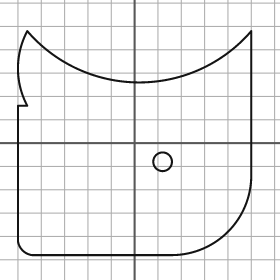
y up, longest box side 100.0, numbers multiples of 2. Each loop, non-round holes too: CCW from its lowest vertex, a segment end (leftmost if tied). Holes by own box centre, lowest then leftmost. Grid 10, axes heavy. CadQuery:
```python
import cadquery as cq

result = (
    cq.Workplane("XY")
    .moveTo(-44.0, -48.0)
    .lineTo(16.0, -48.0)
    .threePointArc((40.0, -38.0), (50.0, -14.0))
    .lineTo(50.0, 48.0)
    .threePointArc((2.0, 26.0), (-46.0, 48.0))
    .threePointArc((-50.0, 32.0), (-46.0, 16.0))
    .lineTo(-50.0, 16.0)
    .lineTo(-50.0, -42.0)
    .threePointArc((-48.0, -46.0), (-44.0, -48.0))
    .close()
    .moveTo(12.0, -8.0)
    .circle(4.0)
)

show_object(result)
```